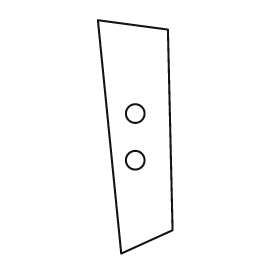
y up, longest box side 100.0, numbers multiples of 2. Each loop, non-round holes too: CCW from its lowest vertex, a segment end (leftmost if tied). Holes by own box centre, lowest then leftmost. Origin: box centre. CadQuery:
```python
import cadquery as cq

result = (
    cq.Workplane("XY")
    .moveTo(-6.0, -50.0)
    .lineTo(16.0, -40.0)
    .lineTo(14.0, 46.0)
    .lineTo(-16.0, 50.0)
    .close()
    .moveTo(0.0, -10.0)
    .circle(4.0)
    .moveTo(0.0, 10.0)
    .circle(4.0)
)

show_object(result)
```